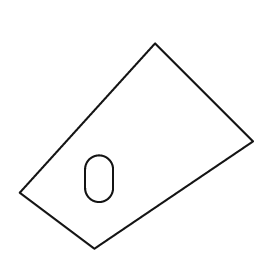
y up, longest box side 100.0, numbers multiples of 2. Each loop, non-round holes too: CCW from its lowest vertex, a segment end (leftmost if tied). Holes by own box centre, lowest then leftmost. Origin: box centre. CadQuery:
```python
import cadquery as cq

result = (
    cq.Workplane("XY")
    .moveTo(-18.0, -44.0)
    .lineTo(50.0, 2.0)
    .lineTo(8.0, 44.0)
    .lineTo(-50.0, -20.0)
    .close()
    .moveTo(-22.0, -18.0)
    .threePointArc((-16.0, -24.0), (-10.0, -18.0))
    .lineTo(-10.0, -10.0)
    .threePointArc((-16.0, -4.0), (-22.0, -10.0))
    .close()
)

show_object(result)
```